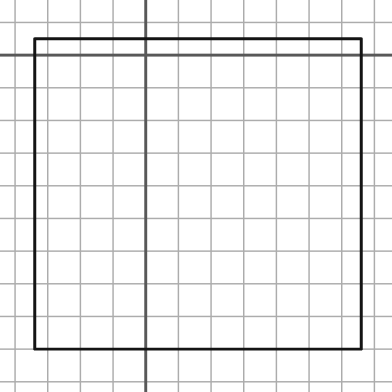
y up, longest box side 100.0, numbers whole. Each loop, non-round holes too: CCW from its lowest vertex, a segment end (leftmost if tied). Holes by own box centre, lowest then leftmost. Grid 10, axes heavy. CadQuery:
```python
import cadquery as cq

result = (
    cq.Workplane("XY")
    .moveTo(-34.0, -90.0)
    .lineTo(66.0, -90.0)
    .lineTo(66.0, 5.0)
    .lineTo(-34.0, 5.0)
    .close()
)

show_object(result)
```